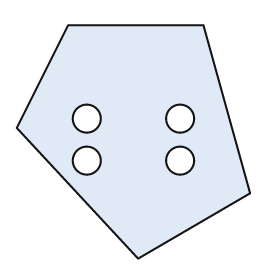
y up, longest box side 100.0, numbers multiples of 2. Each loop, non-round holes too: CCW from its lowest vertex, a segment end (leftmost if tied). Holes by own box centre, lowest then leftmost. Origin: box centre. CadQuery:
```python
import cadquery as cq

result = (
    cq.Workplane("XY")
    .moveTo(2.0, -50.0)
    .lineTo(50.0, -22.0)
    .lineTo(30.0, 50.0)
    .lineTo(-28.0, 50.0)
    .lineTo(-50.0, 6.0)
    .close()
    .moveTo(-20.0, -8.0)
    .circle(6.0)
    .moveTo(20.0, -8.0)
    .circle(6.0)
    .moveTo(-20.0, 10.0)
    .circle(6.0)
    .moveTo(20.0, 10.0)
    .circle(6.0)
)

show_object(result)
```